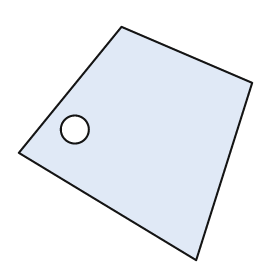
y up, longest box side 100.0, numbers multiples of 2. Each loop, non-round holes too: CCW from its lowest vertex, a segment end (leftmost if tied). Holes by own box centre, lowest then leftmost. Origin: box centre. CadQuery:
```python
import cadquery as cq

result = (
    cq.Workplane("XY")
    .moveTo(26.0, -50.0)
    .lineTo(50.0, 26.0)
    .lineTo(-6.0, 50.0)
    .lineTo(-50.0, -4.0)
    .close()
    .moveTo(-26.0, 6.0)
    .circle(6.0)
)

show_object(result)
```